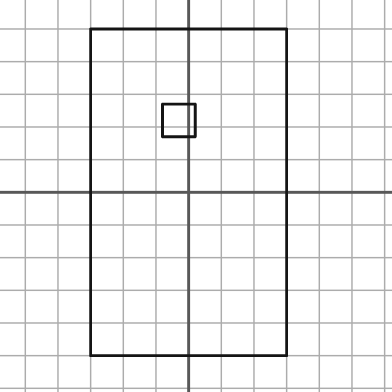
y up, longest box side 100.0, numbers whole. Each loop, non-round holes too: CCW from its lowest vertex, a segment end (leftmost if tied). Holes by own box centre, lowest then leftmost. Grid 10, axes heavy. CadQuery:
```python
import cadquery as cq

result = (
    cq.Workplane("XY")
    .moveTo(-30.0, -50.0)
    .lineTo(30.0, -50.0)
    .lineTo(30.0, 50.0)
    .lineTo(-30.0, 50.0)
    .close()
    .moveTo(-8.0, 17.0)
    .lineTo(2.0, 17.0)
    .lineTo(2.0, 27.0)
    .lineTo(-8.0, 27.0)
    .close()
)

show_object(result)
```